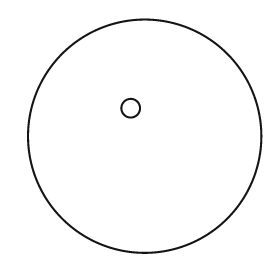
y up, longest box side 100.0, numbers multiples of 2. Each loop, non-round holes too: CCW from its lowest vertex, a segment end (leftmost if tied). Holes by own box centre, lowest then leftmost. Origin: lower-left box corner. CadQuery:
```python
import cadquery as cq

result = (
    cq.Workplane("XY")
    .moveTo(50.0, 50.0)
    .circle(50.0)
    .moveTo(44.0, 62.0)
    .circle(4.0)
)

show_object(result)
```